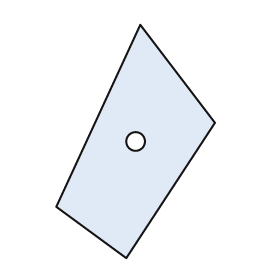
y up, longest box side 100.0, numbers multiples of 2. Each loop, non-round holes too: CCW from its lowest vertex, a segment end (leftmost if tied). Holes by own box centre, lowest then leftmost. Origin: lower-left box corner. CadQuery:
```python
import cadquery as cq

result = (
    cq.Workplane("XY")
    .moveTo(30.0, 0.0)
    .lineTo(68.0, 58.0)
    .lineTo(36.0, 100.0)
    .lineTo(0.0, 22.0)
    .close()
    .moveTo(34.0, 50.0)
    .circle(4.0)
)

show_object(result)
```